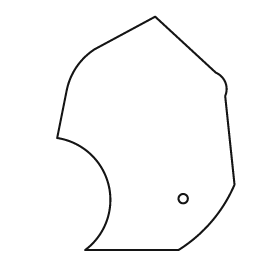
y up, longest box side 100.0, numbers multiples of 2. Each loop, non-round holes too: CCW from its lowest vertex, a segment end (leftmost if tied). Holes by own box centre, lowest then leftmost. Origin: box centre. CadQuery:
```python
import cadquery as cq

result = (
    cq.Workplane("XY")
    .moveTo(-26.0, -50.0)
    .lineTo(14.0, -50.0)
    .threePointArc((28.0, -38.0), (38.0, -22.0))
    .lineTo(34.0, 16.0)
    .threePointArc((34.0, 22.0), (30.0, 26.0))
    .lineTo(4.0, 50.0)
    .lineTo(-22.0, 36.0)
    .threePointArc((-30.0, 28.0), (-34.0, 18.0))
    .lineTo(-38.0, -2.0)
    .threePointArc((-16.0, -22.0), (-26.0, -50.0))
    .close()
    .moveTo(16.0, -28.0)
    .circle(2.0)
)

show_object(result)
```